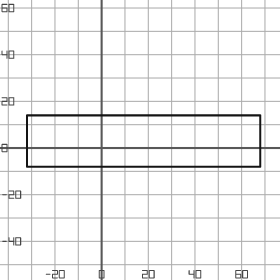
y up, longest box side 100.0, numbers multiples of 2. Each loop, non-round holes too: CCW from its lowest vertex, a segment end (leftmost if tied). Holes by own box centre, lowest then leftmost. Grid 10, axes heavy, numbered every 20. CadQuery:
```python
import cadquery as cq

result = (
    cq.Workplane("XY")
    .moveTo(-32.0, -8.0)
    .lineTo(68.0, -8.0)
    .lineTo(68.0, 14.0)
    .lineTo(-32.0, 14.0)
    .close()
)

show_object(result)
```